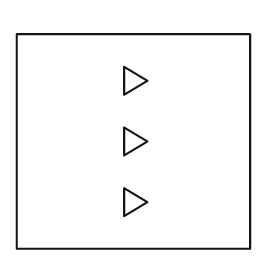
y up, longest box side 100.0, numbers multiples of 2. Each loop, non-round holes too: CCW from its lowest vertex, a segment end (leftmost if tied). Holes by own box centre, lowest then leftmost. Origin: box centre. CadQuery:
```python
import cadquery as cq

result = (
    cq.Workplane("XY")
    .moveTo(-50.0, -46.0)
    .lineTo(50.0, -46.0)
    .lineTo(50.0, 46.0)
    .lineTo(-50.0, 46.0)
    .close()
    .moveTo(-4.0, -32.0)
    .lineTo(6.0, -26.0)
    .lineTo(-4.0, -20.0)
    .close()
    .moveTo(-4.0, -6.0)
    .lineTo(6.0, 0.0)
    .lineTo(-4.0, 6.0)
    .close()
    .moveTo(-4.0, 20.0)
    .lineTo(6.0, 26.0)
    .lineTo(-4.0, 32.0)
    .close()
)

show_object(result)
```